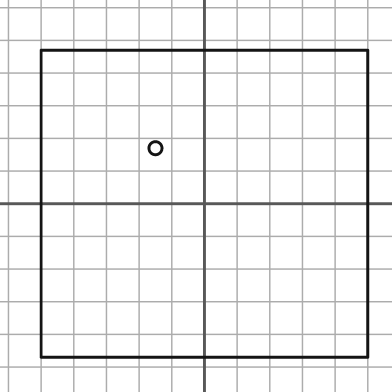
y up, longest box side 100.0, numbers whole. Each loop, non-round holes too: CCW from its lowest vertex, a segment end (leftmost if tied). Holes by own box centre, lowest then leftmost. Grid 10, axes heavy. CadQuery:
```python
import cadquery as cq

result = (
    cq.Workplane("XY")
    .moveTo(-50.0, -47.0)
    .lineTo(50.0, -47.0)
    .lineTo(50.0, 47.0)
    .lineTo(-50.0, 47.0)
    .close()
    .moveTo(-15.0, 17.0)
    .circle(2.0)
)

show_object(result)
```